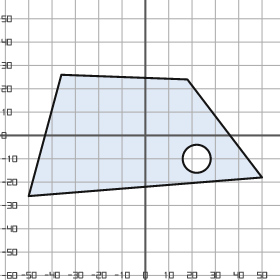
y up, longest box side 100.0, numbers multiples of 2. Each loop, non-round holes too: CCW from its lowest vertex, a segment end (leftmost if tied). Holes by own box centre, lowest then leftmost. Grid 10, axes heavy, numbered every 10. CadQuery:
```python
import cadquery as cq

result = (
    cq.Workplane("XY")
    .moveTo(-50.0, -26.0)
    .lineTo(50.0, -18.0)
    .lineTo(18.0, 24.0)
    .lineTo(-36.0, 26.0)
    .close()
    .moveTo(22.0, -10.0)
    .circle(6.0)
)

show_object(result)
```